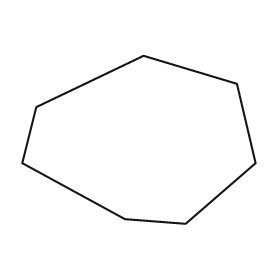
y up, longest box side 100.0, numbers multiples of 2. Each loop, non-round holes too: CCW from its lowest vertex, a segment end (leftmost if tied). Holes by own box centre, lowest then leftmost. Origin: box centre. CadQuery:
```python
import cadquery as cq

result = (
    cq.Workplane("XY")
    .moveTo(20.0, -36.0)
    .lineTo(50.0, -10.0)
    .lineTo(42.0, 24.0)
    .lineTo(2.0, 36.0)
    .lineTo(-44.0, 14.0)
    .lineTo(-50.0, -10.0)
    .lineTo(-6.0, -34.0)
    .close()
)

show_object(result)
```